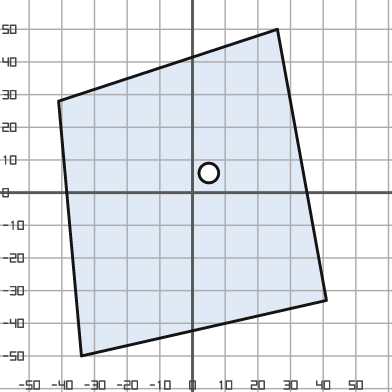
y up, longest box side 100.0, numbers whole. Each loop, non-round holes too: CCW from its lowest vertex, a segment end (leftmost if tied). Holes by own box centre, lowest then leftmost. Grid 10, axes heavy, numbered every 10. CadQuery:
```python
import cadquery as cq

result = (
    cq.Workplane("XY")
    .moveTo(-34.0, -50.0)
    .lineTo(41.0, -33.0)
    .lineTo(26.0, 50.0)
    .lineTo(-41.0, 28.0)
    .close()
    .moveTo(5.0, 6.0)
    .circle(3.0)
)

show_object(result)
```